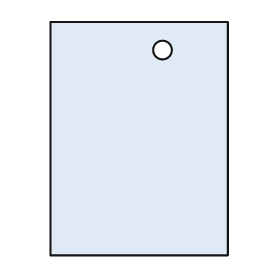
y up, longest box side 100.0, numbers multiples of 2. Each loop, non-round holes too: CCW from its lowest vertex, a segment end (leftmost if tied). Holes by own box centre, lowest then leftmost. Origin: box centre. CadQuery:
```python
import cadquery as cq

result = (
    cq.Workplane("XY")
    .moveTo(-38.0, -50.0)
    .lineTo(38.0, -50.0)
    .lineTo(38.0, 50.0)
    .lineTo(-38.0, 50.0)
    .close()
    .moveTo(10.0, 38.0)
    .circle(4.0)
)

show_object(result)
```